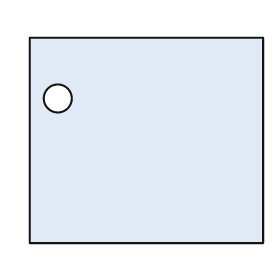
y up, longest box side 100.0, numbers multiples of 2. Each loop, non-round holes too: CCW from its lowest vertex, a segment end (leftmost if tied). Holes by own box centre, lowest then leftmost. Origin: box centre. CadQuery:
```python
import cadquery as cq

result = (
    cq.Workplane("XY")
    .moveTo(-50.0, -44.0)
    .lineTo(50.0, -44.0)
    .lineTo(50.0, 44.0)
    .lineTo(-50.0, 44.0)
    .close()
    .moveTo(-38.0, 18.0)
    .circle(6.0)
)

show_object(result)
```